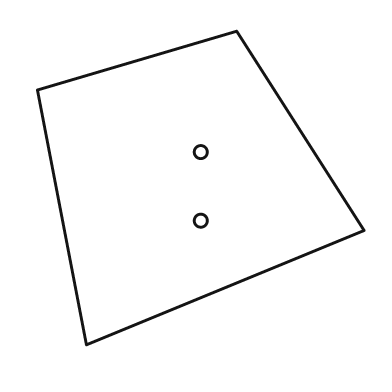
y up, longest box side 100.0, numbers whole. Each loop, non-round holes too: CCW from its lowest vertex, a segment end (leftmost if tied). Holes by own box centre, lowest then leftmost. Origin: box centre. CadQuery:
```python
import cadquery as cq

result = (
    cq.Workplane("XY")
    .moveTo(-35.0, -48.0)
    .lineTo(50.0, -13.0)
    .lineTo(11.0, 48.0)
    .lineTo(-50.0, 30.0)
    .close()
    .moveTo(0.0, -10.0)
    .circle(2.0)
    .moveTo(0.0, 11.0)
    .circle(2.0)
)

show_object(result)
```